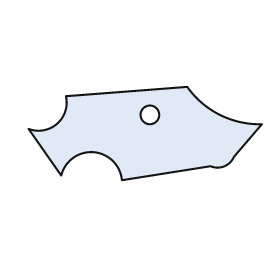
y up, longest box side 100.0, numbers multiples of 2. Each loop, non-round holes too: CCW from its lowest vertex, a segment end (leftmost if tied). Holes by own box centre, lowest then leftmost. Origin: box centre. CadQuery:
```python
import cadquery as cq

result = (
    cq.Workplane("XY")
    .moveTo(-10.0, -20.0)
    .lineTo(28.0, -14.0)
    .threePointArc((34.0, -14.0), (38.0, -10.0))
    .lineTo(50.0, 4.0)
    .threePointArc((32.0, 8.0), (18.0, 20.0))
    .lineTo(-34.0, 16.0)
    .threePointArc((-38.0, 4.0), (-50.0, 2.0))
    .lineTo(-36.0, -18.0)
    .threePointArc((-22.0, -8.0), (-10.0, -20.0))
    .close()
    .moveTo(2.0, 8.0)
    .circle(4.0)
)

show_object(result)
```